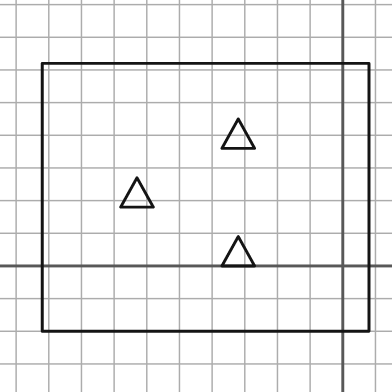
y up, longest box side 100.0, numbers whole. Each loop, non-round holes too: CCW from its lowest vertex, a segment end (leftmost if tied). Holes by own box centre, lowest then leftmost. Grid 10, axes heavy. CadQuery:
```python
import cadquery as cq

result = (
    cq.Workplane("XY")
    .moveTo(-92.0, -20.0)
    .lineTo(8.0, -20.0)
    .lineTo(8.0, 62.0)
    .lineTo(-92.0, 62.0)
    .close()
    .moveTo(-37.0, 0.0)
    .lineTo(-27.0, 0.0)
    .lineTo(-32.0, 9.0)
    .close()
    .moveTo(-68.0, 18.0)
    .lineTo(-58.0, 18.0)
    .lineTo(-63.0, 27.0)
    .close()
    .moveTo(-37.0, 36.0)
    .lineTo(-27.0, 36.0)
    .lineTo(-32.0, 45.0)
    .close()
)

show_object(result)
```